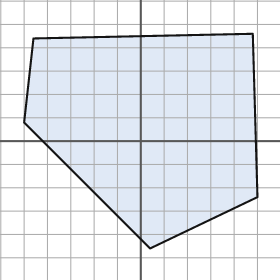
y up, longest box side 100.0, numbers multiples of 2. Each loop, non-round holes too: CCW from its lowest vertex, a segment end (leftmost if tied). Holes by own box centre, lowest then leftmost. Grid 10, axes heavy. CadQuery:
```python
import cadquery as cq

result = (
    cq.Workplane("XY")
    .moveTo(4.0, -46.0)
    .lineTo(50.0, -24.0)
    .lineTo(48.0, 46.0)
    .lineTo(-46.0, 44.0)
    .lineTo(-50.0, 8.0)
    .close()
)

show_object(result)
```